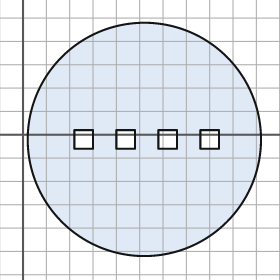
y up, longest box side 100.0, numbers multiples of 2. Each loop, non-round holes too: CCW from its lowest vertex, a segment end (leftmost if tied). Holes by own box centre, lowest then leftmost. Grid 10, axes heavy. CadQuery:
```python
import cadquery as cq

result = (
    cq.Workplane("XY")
    .moveTo(52.0, -2.0)
    .circle(50.0)
    .moveTo(22.0, -6.0)
    .lineTo(30.0, -6.0)
    .lineTo(30.0, 2.0)
    .lineTo(22.0, 2.0)
    .close()
    .moveTo(40.0, -6.0)
    .lineTo(48.0, -6.0)
    .lineTo(48.0, 2.0)
    .lineTo(40.0, 2.0)
    .close()
    .moveTo(58.0, -6.0)
    .lineTo(66.0, -6.0)
    .lineTo(66.0, 2.0)
    .lineTo(58.0, 2.0)
    .close()
    .moveTo(76.0, -6.0)
    .lineTo(84.0, -6.0)
    .lineTo(84.0, 2.0)
    .lineTo(76.0, 2.0)
    .close()
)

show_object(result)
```